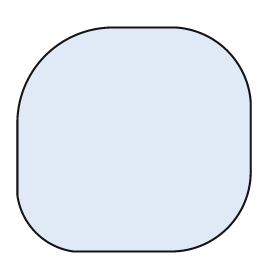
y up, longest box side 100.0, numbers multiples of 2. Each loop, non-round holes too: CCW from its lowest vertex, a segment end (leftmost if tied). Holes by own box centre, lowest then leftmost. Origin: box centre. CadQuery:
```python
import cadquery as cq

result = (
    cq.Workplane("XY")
    .moveTo(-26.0, -48.0)
    .lineTo(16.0, -48.0)
    .threePointArc((40.0, -38.0), (50.0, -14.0))
    .lineTo(50.0, 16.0)
    .threePointArc((40.0, 38.0), (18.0, 48.0))
    .lineTo(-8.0, 48.0)
    .threePointArc((-38.0, 36.0), (-50.0, 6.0))
    .lineTo(-50.0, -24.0)
    .threePointArc((-42.0, -40.0), (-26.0, -48.0))
    .close()
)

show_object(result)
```